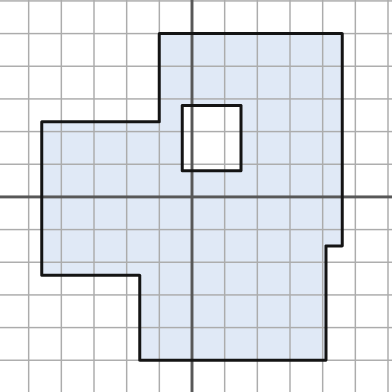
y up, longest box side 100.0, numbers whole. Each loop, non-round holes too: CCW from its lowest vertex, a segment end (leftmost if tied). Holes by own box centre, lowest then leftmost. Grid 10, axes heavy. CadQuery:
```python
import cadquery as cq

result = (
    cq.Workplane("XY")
    .moveTo(-16.0, -50.0)
    .lineTo(41.0, -50.0)
    .lineTo(41.0, -15.0)
    .lineTo(46.0, -15.0)
    .lineTo(46.0, 50.0)
    .lineTo(-10.0, 50.0)
    .lineTo(-10.0, 23.0)
    .lineTo(-46.0, 23.0)
    .lineTo(-46.0, -24.0)
    .lineTo(-16.0, -24.0)
    .close()
    .moveTo(-3.0, 8.0)
    .lineTo(15.0, 8.0)
    .lineTo(15.0, 28.0)
    .lineTo(-3.0, 28.0)
    .close()
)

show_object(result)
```